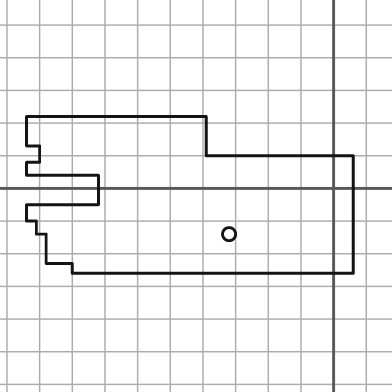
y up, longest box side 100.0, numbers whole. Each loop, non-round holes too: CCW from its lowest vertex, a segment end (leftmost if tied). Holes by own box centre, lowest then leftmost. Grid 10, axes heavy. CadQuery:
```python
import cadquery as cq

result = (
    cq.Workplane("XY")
    .moveTo(-80.0, -26.0)
    .lineTo(6.0, -26.0)
    .lineTo(6.0, 10.0)
    .lineTo(-39.0, 10.0)
    .lineTo(-39.0, 22.0)
    .lineTo(-94.0, 22.0)
    .lineTo(-94.0, 13.0)
    .lineTo(-90.0, 13.0)
    .lineTo(-90.0, 8.0)
    .lineTo(-94.0, 8.0)
    .lineTo(-94.0, 4.0)
    .lineTo(-72.0, 4.0)
    .lineTo(-72.0, -5.0)
    .lineTo(-94.0, -5.0)
    .lineTo(-94.0, -10.0)
    .lineTo(-91.0, -10.0)
    .lineTo(-91.0, -14.0)
    .lineTo(-88.0, -14.0)
    .lineTo(-88.0, -23.0)
    .lineTo(-80.0, -23.0)
    .close()
    .moveTo(-32.0, -14.0)
    .circle(2.0)
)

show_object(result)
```